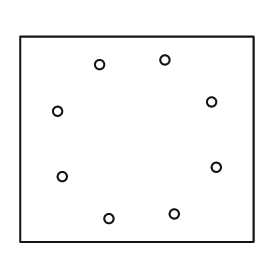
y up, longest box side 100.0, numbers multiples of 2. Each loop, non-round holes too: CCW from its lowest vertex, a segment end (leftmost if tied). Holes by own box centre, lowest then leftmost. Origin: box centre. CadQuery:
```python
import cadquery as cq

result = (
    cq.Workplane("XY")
    .moveTo(-50.0, -44.0)
    .lineTo(50.0, -44.0)
    .lineTo(50.0, 44.0)
    .lineTo(-50.0, 44.0)
    .close()
    .moveTo(-12.0, -34.0)
    .circle(2.0)
    .moveTo(16.0, -32.0)
    .circle(2.0)
    .moveTo(-32.0, -16.0)
    .circle(2.0)
    .moveTo(34.0, -12.0)
    .circle(2.0)
    .moveTo(-34.0, 12.0)
    .circle(2.0)
    .moveTo(32.0, 16.0)
    .circle(2.0)
    .moveTo(-16.0, 32.0)
    .circle(2.0)
    .moveTo(12.0, 34.0)
    .circle(2.0)
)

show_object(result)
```